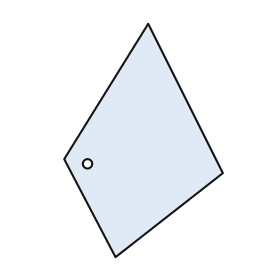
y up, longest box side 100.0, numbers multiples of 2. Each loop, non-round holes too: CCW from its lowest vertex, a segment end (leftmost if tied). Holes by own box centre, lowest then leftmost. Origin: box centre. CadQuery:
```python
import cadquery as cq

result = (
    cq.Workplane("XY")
    .moveTo(-12.0, -50.0)
    .lineTo(34.0, -14.0)
    .lineTo(2.0, 50.0)
    .lineTo(-34.0, -8.0)
    .close()
    .moveTo(-24.0, -10.0)
    .circle(2.0)
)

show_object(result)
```